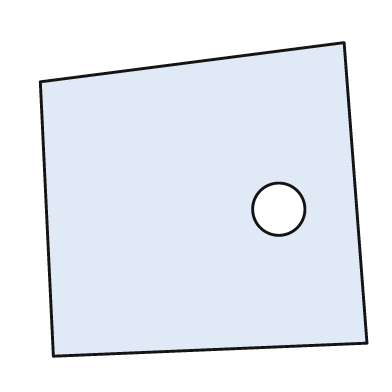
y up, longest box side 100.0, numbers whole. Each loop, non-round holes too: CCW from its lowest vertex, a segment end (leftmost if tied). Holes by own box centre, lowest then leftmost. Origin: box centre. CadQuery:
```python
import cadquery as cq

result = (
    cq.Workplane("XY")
    .moveTo(-46.0, -48.0)
    .lineTo(50.0, -44.0)
    .lineTo(43.0, 48.0)
    .lineTo(-50.0, 36.0)
    .close()
    .moveTo(23.0, -3.0)
    .circle(8.0)
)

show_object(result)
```